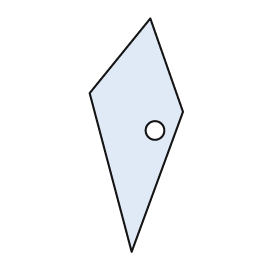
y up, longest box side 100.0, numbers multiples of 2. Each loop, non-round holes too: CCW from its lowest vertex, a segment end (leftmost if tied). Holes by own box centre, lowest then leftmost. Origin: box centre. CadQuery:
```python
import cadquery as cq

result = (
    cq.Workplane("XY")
    .moveTo(-2.0, -50.0)
    .lineTo(20.0, 10.0)
    .lineTo(6.0, 50.0)
    .lineTo(-20.0, 18.0)
    .close()
    .moveTo(8.0, 2.0)
    .circle(4.0)
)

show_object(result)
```